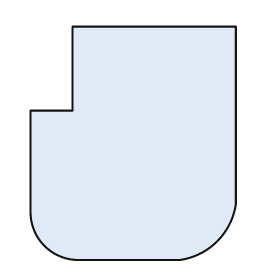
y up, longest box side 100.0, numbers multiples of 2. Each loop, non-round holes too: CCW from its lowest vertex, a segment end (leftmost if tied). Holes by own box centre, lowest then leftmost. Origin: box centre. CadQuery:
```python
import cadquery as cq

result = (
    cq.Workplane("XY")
    .moveTo(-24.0, -50.0)
    .lineTo(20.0, -50.0)
    .threePointArc((36.0, -42.0), (44.0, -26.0))
    .lineTo(44.0, 50.0)
    .lineTo(-26.0, 50.0)
    .lineTo(-26.0, 14.0)
    .lineTo(-44.0, 14.0)
    .lineTo(-44.0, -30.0)
    .threePointArc((-38.0, -44.0), (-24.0, -50.0))
    .close()
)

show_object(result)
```